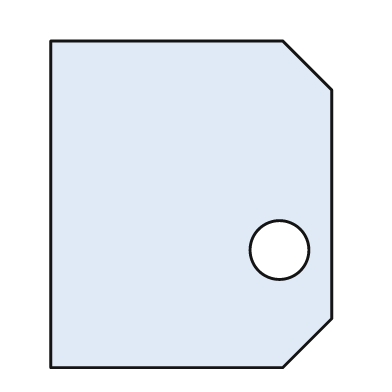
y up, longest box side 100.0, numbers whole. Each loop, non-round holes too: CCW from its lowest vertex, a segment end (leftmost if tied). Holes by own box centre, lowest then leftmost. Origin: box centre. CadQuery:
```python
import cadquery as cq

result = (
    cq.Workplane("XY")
    .moveTo(-43.0, -50.0)
    .lineTo(28.0, -50.0)
    .lineTo(43.0, -35.0)
    .lineTo(43.0, 35.0)
    .lineTo(28.0, 50.0)
    .lineTo(-43.0, 50.0)
    .close()
    .moveTo(27.0, -14.0)
    .circle(9.0)
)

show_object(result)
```